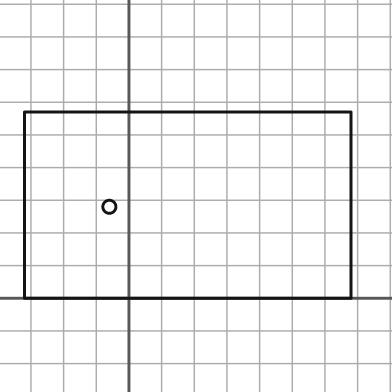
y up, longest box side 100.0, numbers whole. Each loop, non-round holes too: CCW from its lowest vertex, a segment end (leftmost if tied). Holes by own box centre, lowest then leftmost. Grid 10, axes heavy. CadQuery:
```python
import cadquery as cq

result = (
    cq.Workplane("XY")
    .moveTo(-32.0, 0.0)
    .lineTo(68.0, 0.0)
    .lineTo(68.0, 57.0)
    .lineTo(-32.0, 57.0)
    .close()
    .moveTo(-6.0, 28.0)
    .circle(2.0)
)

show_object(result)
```